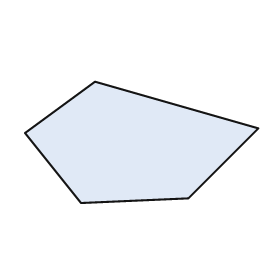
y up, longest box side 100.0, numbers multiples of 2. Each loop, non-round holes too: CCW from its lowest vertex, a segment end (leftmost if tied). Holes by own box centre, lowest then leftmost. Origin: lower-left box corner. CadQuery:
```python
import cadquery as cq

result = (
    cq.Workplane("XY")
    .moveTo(24.0, 0.0)
    .lineTo(70.0, 2.0)
    .lineTo(100.0, 32.0)
    .lineTo(30.0, 52.0)
    .lineTo(0.0, 30.0)
    .close()
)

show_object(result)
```